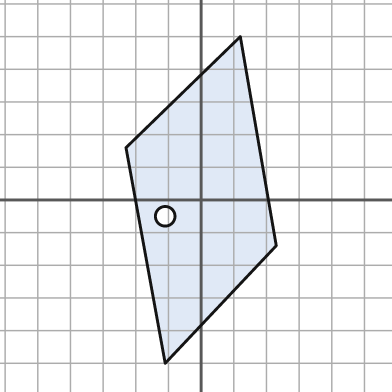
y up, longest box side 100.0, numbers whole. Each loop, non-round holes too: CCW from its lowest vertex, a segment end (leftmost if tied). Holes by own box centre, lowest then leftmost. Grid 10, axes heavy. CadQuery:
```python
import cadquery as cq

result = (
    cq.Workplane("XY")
    .moveTo(-11.0, -50.0)
    .lineTo(23.0, -14.0)
    .lineTo(12.0, 50.0)
    .lineTo(-23.0, 16.0)
    .close()
    .moveTo(-11.0, -5.0)
    .circle(3.0)
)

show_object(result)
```